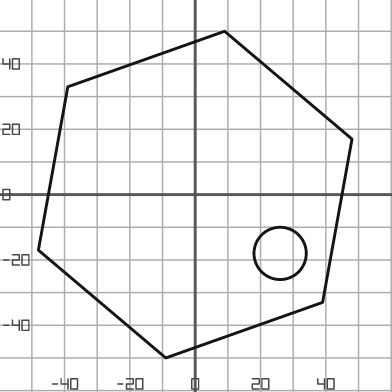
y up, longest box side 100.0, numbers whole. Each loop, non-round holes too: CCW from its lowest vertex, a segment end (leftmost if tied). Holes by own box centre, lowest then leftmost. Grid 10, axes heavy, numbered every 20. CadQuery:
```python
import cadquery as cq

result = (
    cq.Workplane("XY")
    .moveTo(-9.0, -50.0)
    .lineTo(39.0, -33.0)
    .lineTo(48.0, 17.0)
    .lineTo(9.0, 50.0)
    .lineTo(-39.0, 33.0)
    .lineTo(-48.0, -17.0)
    .close()
    .moveTo(26.0, -18.0)
    .circle(8.0)
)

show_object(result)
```